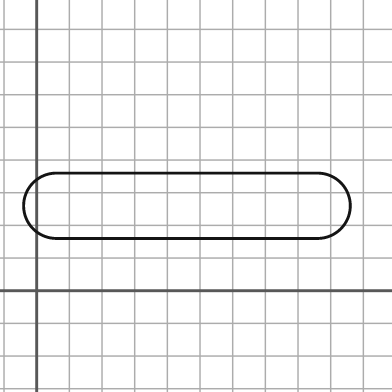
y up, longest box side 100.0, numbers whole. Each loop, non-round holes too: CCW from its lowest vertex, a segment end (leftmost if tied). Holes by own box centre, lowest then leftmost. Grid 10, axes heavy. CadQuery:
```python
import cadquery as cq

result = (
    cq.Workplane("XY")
    .moveTo(6.0, 16.0)
    .lineTo(86.0, 16.0)
    .threePointArc((96.0, 26.0), (86.0, 36.0))
    .lineTo(6.0, 36.0)
    .threePointArc((-4.0, 26.0), (6.0, 16.0))
    .close()
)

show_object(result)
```